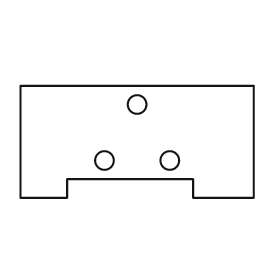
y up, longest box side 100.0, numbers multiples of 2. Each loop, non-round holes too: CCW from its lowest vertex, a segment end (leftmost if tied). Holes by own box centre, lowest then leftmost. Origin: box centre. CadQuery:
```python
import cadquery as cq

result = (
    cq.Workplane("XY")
    .moveTo(-50.0, -24.0)
    .lineTo(-30.0, -24.0)
    .lineTo(-30.0, -16.0)
    .lineTo(24.0, -16.0)
    .lineTo(24.0, -24.0)
    .lineTo(50.0, -24.0)
    .lineTo(50.0, 24.0)
    .lineTo(-50.0, 24.0)
    .close()
    .moveTo(-14.0, -8.0)
    .circle(4.0)
    .moveTo(14.0, -8.0)
    .circle(4.0)
    .moveTo(0.0, 16.0)
    .circle(4.0)
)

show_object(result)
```